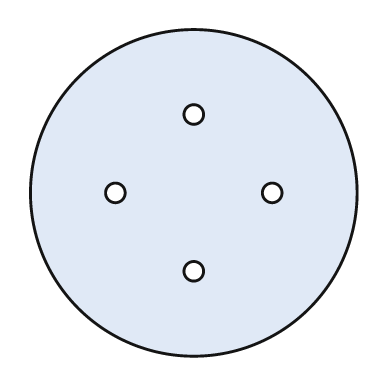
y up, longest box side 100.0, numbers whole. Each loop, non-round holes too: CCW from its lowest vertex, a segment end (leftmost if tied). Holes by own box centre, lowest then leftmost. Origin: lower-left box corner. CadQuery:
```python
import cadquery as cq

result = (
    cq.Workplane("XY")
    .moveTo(50.0, 50.0)
    .circle(50.0)
    .moveTo(50.0, 26.0)
    .circle(3.0)
    .moveTo(26.0, 50.0)
    .circle(3.0)
    .moveTo(74.0, 50.0)
    .circle(3.0)
    .moveTo(50.0, 74.0)
    .circle(3.0)
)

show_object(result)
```